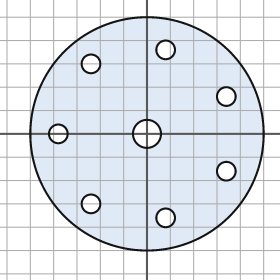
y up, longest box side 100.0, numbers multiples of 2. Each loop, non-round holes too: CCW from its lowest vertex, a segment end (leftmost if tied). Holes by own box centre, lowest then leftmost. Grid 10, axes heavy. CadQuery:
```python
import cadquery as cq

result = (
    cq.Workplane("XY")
    .moveTo(0.0, 0.0)
    .circle(50.0)
    .moveTo(8.0, -36.0)
    .circle(4.0)
    .moveTo(-24.0, -30.0)
    .circle(4.0)
    .moveTo(34.0, -16.0)
    .circle(4.0)
    .moveTo(-38.0, 0.0)
    .circle(4.0)
    .moveTo(0.0, 0.0)
    .circle(6.0)
    .moveTo(34.0, 16.0)
    .circle(4.0)
    .moveTo(-24.0, 30.0)
    .circle(4.0)
    .moveTo(8.0, 36.0)
    .circle(4.0)
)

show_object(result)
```